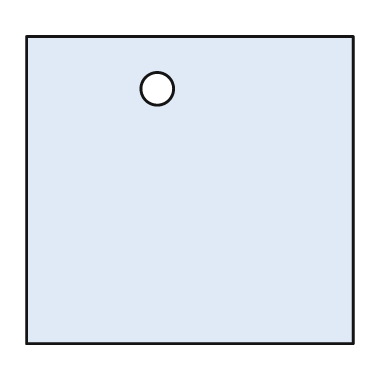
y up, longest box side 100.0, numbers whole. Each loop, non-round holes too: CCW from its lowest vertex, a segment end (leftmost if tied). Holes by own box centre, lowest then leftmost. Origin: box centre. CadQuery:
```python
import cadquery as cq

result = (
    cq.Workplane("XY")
    .moveTo(-50.0, -47.0)
    .lineTo(50.0, -47.0)
    .lineTo(50.0, 47.0)
    .lineTo(-50.0, 47.0)
    .close()
    .moveTo(-10.0, 31.0)
    .circle(5.0)
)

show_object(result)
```